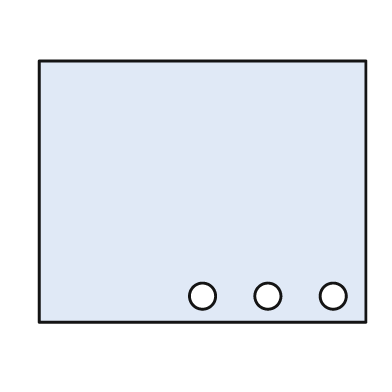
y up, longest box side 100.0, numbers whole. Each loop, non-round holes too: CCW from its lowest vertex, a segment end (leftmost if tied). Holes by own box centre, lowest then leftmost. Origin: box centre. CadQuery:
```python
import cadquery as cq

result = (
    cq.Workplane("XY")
    .moveTo(-50.0, -40.0)
    .lineTo(50.0, -40.0)
    .lineTo(50.0, 40.0)
    .lineTo(-50.0, 40.0)
    .close()
    .moveTo(0.0, -32.0)
    .circle(4.0)
    .moveTo(20.0, -32.0)
    .circle(4.0)
    .moveTo(40.0, -32.0)
    .circle(4.0)
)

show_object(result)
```